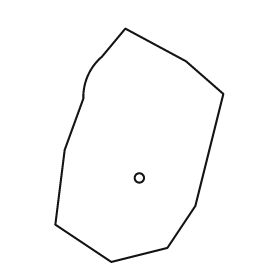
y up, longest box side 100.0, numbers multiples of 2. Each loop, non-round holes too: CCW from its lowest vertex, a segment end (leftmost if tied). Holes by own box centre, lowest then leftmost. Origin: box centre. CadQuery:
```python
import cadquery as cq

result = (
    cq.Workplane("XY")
    .moveTo(-12.0, -50.0)
    .lineTo(12.0, -44.0)
    .lineTo(24.0, -26.0)
    .lineTo(36.0, 22.0)
    .lineTo(20.0, 36.0)
    .lineTo(-6.0, 50.0)
    .lineTo(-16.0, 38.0)
    .threePointArc((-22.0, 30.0), (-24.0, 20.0))
    .lineTo(-32.0, -2.0)
    .lineTo(-36.0, -34.0)
    .close()
    .moveTo(0.0, -14.0)
    .circle(2.0)
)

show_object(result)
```